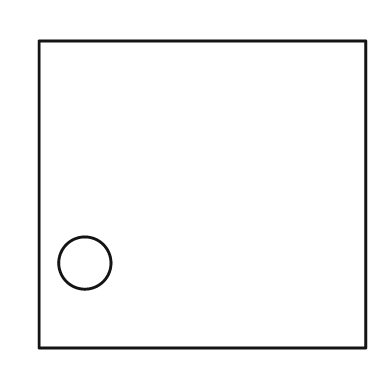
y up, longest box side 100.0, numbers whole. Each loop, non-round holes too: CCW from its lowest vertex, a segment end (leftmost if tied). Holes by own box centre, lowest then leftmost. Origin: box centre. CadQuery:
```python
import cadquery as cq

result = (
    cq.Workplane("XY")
    .moveTo(-50.0, -47.0)
    .lineTo(50.0, -47.0)
    .lineTo(50.0, 47.0)
    .lineTo(-50.0, 47.0)
    .close()
    .moveTo(-36.0, -21.0)
    .circle(8.0)
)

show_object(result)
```